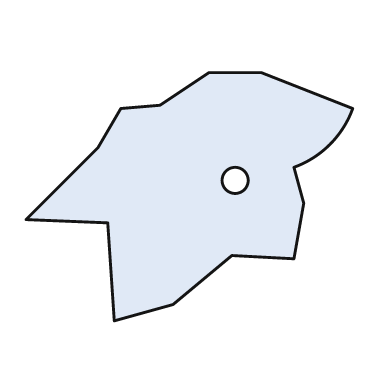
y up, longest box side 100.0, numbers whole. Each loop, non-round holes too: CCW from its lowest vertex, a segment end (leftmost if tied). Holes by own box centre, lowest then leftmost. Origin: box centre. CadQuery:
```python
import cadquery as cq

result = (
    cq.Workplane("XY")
    .moveTo(-23.0, -38.0)
    .lineTo(-5.0, -33.0)
    .lineTo(13.0, -18.0)
    .lineTo(32.0, -19.0)
    .lineTo(35.0, -2.0)
    .lineTo(32.0, 9.0)
    .threePointArc((43.0, 16.0), (50.0, 27.0))
    .lineTo(22.0, 38.0)
    .lineTo(6.0, 38.0)
    .lineTo(-9.0, 28.0)
    .lineTo(-21.0, 27.0)
    .lineTo(-28.0, 15.0)
    .lineTo(-50.0, -7.0)
    .lineTo(-25.0, -8.0)
    .close()
    .moveTo(14.0, 5.0)
    .circle(4.0)
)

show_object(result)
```